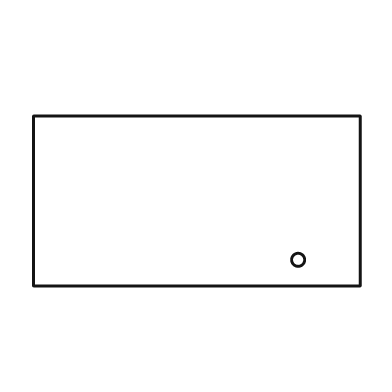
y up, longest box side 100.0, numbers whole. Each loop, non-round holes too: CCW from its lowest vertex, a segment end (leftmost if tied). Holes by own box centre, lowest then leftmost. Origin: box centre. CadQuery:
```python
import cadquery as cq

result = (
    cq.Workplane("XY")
    .moveTo(-50.0, -26.0)
    .lineTo(50.0, -26.0)
    .lineTo(50.0, 26.0)
    .lineTo(-50.0, 26.0)
    .close()
    .moveTo(31.0, -18.0)
    .circle(2.0)
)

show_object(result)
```